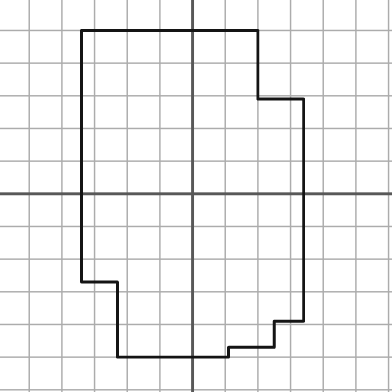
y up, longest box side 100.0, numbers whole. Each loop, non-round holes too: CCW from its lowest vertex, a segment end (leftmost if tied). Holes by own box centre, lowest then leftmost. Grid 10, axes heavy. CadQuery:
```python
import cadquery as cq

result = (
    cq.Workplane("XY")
    .moveTo(-23.0, -50.0)
    .lineTo(11.0, -50.0)
    .lineTo(11.0, -47.0)
    .lineTo(25.0, -47.0)
    .lineTo(25.0, -39.0)
    .lineTo(34.0, -39.0)
    .lineTo(34.0, 29.0)
    .lineTo(20.0, 29.0)
    .lineTo(20.0, 50.0)
    .lineTo(-34.0, 50.0)
    .lineTo(-34.0, -27.0)
    .lineTo(-23.0, -27.0)
    .close()
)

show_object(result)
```